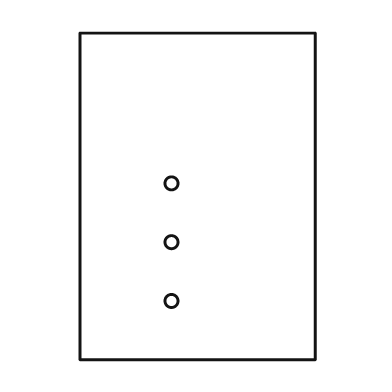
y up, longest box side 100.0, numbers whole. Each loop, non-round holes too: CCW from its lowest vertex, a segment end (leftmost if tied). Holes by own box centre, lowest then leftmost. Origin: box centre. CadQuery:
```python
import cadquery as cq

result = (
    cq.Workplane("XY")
    .moveTo(-36.0, -50.0)
    .lineTo(36.0, -50.0)
    .lineTo(36.0, 50.0)
    .lineTo(-36.0, 50.0)
    .close()
    .moveTo(-8.0, -32.0)
    .circle(2.0)
    .moveTo(-8.0, -14.0)
    .circle(2.0)
    .moveTo(-8.0, 4.0)
    .circle(2.0)
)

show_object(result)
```